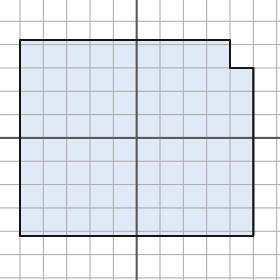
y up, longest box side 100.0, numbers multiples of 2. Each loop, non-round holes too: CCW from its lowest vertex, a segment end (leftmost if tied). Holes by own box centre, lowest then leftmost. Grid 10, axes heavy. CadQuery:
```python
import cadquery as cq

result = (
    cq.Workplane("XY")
    .moveTo(-50.0, -42.0)
    .lineTo(50.0, -42.0)
    .lineTo(50.0, 30.0)
    .lineTo(40.0, 30.0)
    .lineTo(40.0, 42.0)
    .lineTo(-50.0, 42.0)
    .close()
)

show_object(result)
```